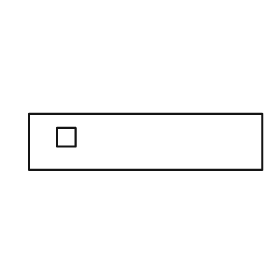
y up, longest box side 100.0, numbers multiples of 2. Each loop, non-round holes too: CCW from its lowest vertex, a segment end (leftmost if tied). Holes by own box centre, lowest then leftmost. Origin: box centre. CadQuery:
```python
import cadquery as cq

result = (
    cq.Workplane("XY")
    .moveTo(-50.0, -12.0)
    .lineTo(50.0, -12.0)
    .lineTo(50.0, 12.0)
    .lineTo(-50.0, 12.0)
    .close()
    .moveTo(-38.0, -2.0)
    .lineTo(-30.0, -2.0)
    .lineTo(-30.0, 6.0)
    .lineTo(-38.0, 6.0)
    .close()
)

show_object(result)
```